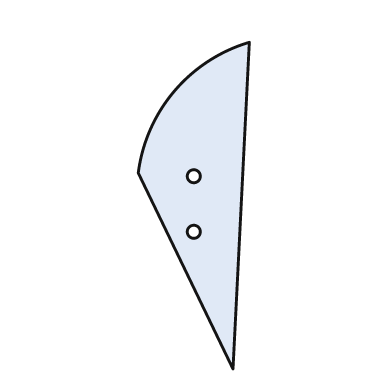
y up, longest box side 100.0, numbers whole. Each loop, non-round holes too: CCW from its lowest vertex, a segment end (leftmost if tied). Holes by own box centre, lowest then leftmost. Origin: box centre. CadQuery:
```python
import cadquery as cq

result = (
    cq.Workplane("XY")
    .moveTo(12.0, -50.0)
    .lineTo(17.0, 50.0)
    .threePointArc((-6.0, 35.0), (-17.0, 10.0))
    .close()
    .moveTo(0.0, -8.0)
    .circle(2.0)
    .moveTo(0.0, 9.0)
    .circle(2.0)
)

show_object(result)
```